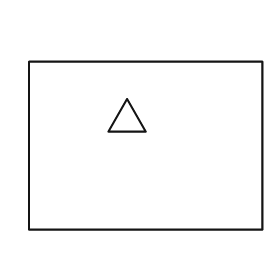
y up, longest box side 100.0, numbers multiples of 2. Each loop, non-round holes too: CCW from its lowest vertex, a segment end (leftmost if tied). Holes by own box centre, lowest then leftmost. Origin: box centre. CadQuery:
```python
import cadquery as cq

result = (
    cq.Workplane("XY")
    .moveTo(-50.0, -36.0)
    .lineTo(50.0, -36.0)
    .lineTo(50.0, 36.0)
    .lineTo(-50.0, 36.0)
    .close()
    .moveTo(-16.0, 6.0)
    .lineTo(0.0, 6.0)
    .lineTo(-8.0, 20.0)
    .close()
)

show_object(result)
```